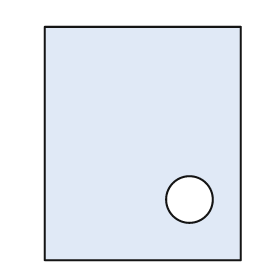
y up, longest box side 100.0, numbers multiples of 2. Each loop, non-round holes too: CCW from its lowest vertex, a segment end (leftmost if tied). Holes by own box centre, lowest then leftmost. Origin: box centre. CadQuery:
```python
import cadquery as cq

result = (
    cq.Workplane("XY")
    .moveTo(-42.0, -50.0)
    .lineTo(42.0, -50.0)
    .lineTo(42.0, 50.0)
    .lineTo(-42.0, 50.0)
    .close()
    .moveTo(20.0, -24.0)
    .circle(10.0)
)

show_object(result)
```